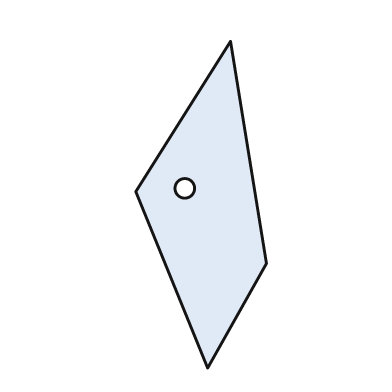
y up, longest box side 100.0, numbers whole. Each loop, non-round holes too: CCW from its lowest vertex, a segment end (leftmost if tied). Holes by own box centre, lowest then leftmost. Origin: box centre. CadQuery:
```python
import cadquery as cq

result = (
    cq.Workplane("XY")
    .moveTo(2.0, -50.0)
    .lineTo(20.0, -18.0)
    .lineTo(9.0, 50.0)
    .lineTo(-20.0, 4.0)
    .close()
    .moveTo(-5.0, 5.0)
    .circle(3.0)
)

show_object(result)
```